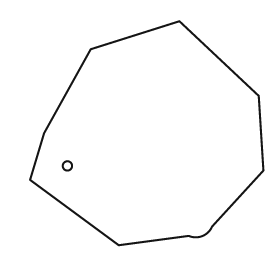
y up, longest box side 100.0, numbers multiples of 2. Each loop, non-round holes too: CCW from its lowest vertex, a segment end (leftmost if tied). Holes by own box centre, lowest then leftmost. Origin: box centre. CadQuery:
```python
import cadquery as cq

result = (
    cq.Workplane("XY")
    .moveTo(-12.0, -48.0)
    .lineTo(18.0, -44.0)
    .threePointArc((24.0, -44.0), (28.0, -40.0))
    .lineTo(50.0, -16.0)
    .lineTo(48.0, 16.0)
    .lineTo(14.0, 48.0)
    .lineTo(-24.0, 36.0)
    .lineTo(-44.0, 0.0)
    .lineTo(-50.0, -20.0)
    .close()
    .moveTo(-34.0, -14.0)
    .circle(2.0)
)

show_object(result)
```